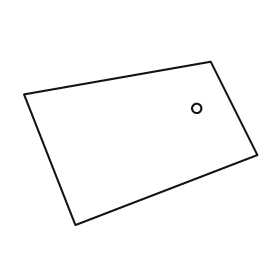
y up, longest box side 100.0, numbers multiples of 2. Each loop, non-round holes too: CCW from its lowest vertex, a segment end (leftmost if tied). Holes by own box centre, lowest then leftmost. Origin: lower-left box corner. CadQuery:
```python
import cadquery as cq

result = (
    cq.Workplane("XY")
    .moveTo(22.0, 0.0)
    .lineTo(100.0, 30.0)
    .lineTo(80.0, 70.0)
    .lineTo(0.0, 56.0)
    .close()
    .moveTo(74.0, 50.0)
    .circle(2.0)
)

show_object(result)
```